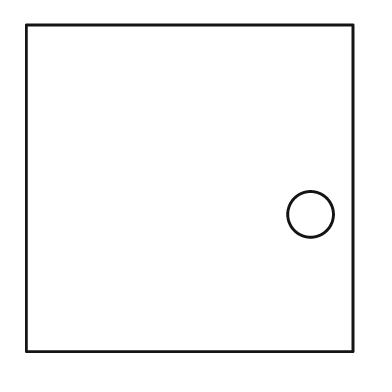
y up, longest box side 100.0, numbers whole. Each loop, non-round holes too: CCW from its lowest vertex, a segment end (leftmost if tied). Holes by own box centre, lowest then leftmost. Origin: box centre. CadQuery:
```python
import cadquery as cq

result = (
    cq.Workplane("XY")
    .moveTo(-50.0, -50.0)
    .lineTo(50.0, -50.0)
    .lineTo(50.0, 50.0)
    .lineTo(-50.0, 50.0)
    .close()
    .moveTo(37.0, -8.0)
    .circle(7.0)
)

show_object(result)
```